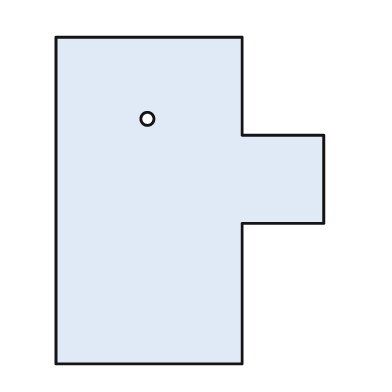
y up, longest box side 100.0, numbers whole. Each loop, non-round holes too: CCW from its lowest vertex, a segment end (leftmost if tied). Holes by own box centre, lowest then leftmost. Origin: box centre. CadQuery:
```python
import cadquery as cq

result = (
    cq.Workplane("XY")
    .moveTo(-41.0, -50.0)
    .lineTo(16.0, -50.0)
    .lineTo(16.0, -7.0)
    .lineTo(41.0, -7.0)
    .lineTo(41.0, 20.0)
    .lineTo(16.0, 20.0)
    .lineTo(16.0, 50.0)
    .lineTo(-41.0, 50.0)
    .close()
    .moveTo(-13.0, 25.0)
    .circle(2.0)
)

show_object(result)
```